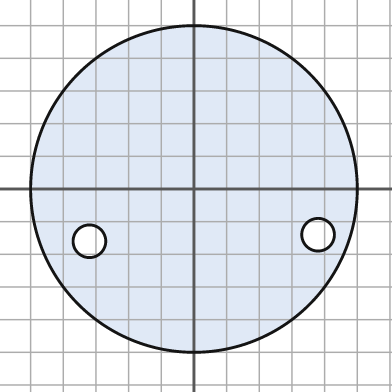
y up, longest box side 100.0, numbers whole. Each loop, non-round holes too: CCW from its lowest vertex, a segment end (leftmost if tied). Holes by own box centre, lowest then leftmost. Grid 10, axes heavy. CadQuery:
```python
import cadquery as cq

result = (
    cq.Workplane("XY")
    .moveTo(0.0, 0.0)
    .circle(50.0)
    .moveTo(-32.0, -16.0)
    .circle(5.0)
    .moveTo(38.0, -14.0)
    .circle(5.0)
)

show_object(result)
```